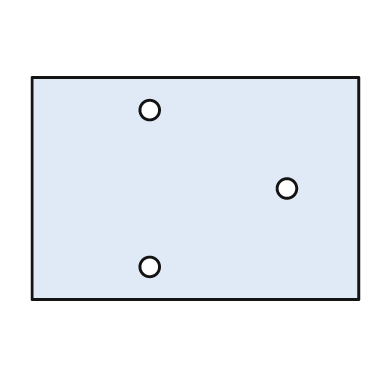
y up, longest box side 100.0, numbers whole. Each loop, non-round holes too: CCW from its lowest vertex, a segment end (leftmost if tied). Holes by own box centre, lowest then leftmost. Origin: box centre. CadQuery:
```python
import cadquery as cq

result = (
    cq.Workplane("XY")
    .moveTo(-50.0, -34.0)
    .lineTo(50.0, -34.0)
    .lineTo(50.0, 34.0)
    .lineTo(-50.0, 34.0)
    .close()
    .moveTo(-14.0, -24.0)
    .circle(3.0)
    .moveTo(28.0, 0.0)
    .circle(3.0)
    .moveTo(-14.0, 24.0)
    .circle(3.0)
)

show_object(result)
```